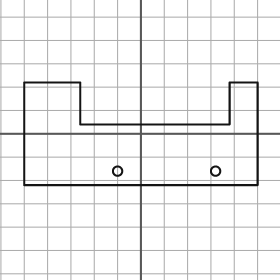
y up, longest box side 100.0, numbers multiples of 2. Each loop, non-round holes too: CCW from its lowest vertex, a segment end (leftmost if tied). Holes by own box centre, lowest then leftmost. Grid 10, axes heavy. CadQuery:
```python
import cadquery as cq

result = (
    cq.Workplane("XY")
    .moveTo(-50.0, -22.0)
    .lineTo(50.0, -22.0)
    .lineTo(50.0, 22.0)
    .lineTo(38.0, 22.0)
    .lineTo(38.0, 4.0)
    .lineTo(-26.0, 4.0)
    .lineTo(-26.0, 22.0)
    .lineTo(-50.0, 22.0)
    .close()
    .moveTo(-10.0, -16.0)
    .circle(2.0)
    .moveTo(32.0, -16.0)
    .circle(2.0)
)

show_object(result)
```